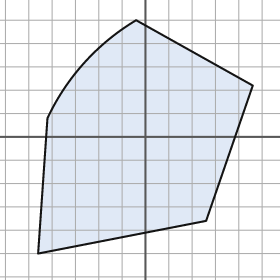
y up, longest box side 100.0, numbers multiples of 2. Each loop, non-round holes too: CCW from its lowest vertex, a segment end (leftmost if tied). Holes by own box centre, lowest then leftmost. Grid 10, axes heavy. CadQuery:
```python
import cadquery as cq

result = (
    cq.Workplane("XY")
    .moveTo(-46.0, -50.0)
    .lineTo(26.0, -36.0)
    .lineTo(46.0, 22.0)
    .lineTo(-4.0, 50.0)
    .threePointArc((-26.0, 32.0), (-42.0, 8.0))
    .close()
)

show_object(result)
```